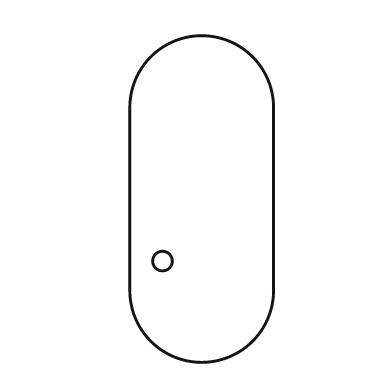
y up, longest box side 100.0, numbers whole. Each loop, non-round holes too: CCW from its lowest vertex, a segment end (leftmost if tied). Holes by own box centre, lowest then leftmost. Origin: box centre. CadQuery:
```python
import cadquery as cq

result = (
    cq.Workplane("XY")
    .moveTo(-22.0, -28.0)
    .threePointArc((0.0, -50.0), (22.0, -28.0))
    .lineTo(22.0, 28.0)
    .threePointArc((0.0, 50.0), (-22.0, 28.0))
    .close()
    .moveTo(-12.0, -19.0)
    .circle(3.0)
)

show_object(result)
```